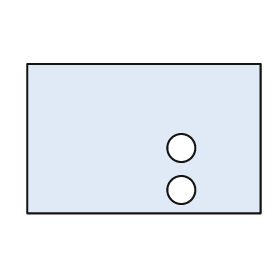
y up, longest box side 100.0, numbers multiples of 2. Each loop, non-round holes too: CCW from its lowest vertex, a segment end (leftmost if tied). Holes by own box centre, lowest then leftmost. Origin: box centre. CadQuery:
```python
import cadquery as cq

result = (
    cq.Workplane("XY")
    .moveTo(-50.0, -32.0)
    .lineTo(50.0, -32.0)
    .lineTo(50.0, 32.0)
    .lineTo(-50.0, 32.0)
    .close()
    .moveTo(16.0, -22.0)
    .circle(6.0)
    .moveTo(16.0, -4.0)
    .circle(6.0)
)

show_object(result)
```